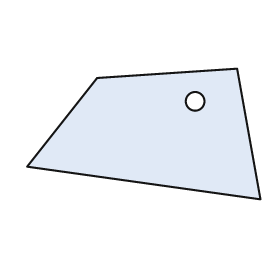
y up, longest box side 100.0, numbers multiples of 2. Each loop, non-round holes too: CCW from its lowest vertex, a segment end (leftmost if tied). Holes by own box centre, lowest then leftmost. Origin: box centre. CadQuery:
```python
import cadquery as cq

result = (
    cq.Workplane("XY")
    .moveTo(50.0, -28.0)
    .lineTo(40.0, 28.0)
    .lineTo(-20.0, 24.0)
    .lineTo(-50.0, -14.0)
    .close()
    .moveTo(22.0, 14.0)
    .circle(4.0)
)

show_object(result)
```